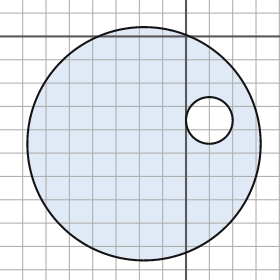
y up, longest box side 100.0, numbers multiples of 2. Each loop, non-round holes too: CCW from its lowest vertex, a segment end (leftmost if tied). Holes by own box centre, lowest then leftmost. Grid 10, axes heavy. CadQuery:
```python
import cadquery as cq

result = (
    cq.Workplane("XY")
    .moveTo(-18.0, -46.0)
    .circle(50.0)
    .moveTo(10.0, -36.0)
    .circle(10.0)
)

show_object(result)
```